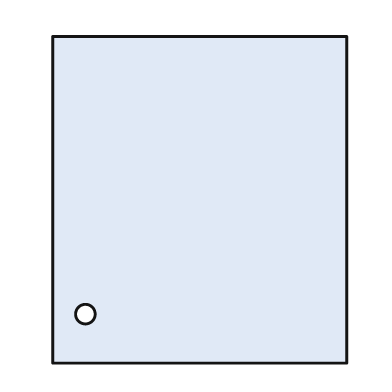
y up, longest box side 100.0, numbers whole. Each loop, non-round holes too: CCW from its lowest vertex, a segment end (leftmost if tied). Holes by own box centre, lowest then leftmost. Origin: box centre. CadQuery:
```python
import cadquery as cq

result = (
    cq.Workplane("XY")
    .moveTo(-45.0, -50.0)
    .lineTo(45.0, -50.0)
    .lineTo(45.0, 50.0)
    .lineTo(-45.0, 50.0)
    .close()
    .moveTo(-35.0, -35.0)
    .circle(3.0)
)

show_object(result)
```